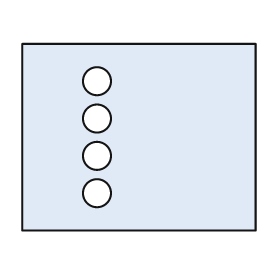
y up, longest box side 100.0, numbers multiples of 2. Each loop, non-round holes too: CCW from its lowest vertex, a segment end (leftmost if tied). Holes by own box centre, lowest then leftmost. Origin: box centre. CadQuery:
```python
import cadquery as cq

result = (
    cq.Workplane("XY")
    .moveTo(-50.0, -40.0)
    .lineTo(50.0, -40.0)
    .lineTo(50.0, 40.0)
    .lineTo(-50.0, 40.0)
    .close()
    .moveTo(-18.0, -24.0)
    .circle(6.0)
    .moveTo(-18.0, -8.0)
    .circle(6.0)
    .moveTo(-18.0, 8.0)
    .circle(6.0)
    .moveTo(-18.0, 24.0)
    .circle(6.0)
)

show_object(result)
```